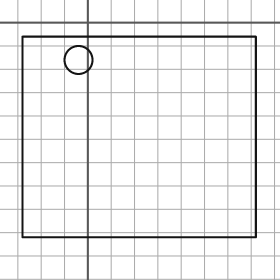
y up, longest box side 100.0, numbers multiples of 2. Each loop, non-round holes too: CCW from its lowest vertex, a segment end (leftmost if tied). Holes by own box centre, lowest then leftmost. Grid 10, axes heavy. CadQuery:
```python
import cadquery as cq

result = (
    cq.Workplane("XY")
    .moveTo(-28.0, -92.0)
    .lineTo(72.0, -92.0)
    .lineTo(72.0, -6.0)
    .lineTo(-28.0, -6.0)
    .close()
    .moveTo(-4.0, -16.0)
    .circle(6.0)
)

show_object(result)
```